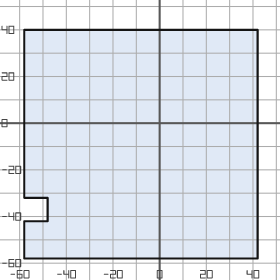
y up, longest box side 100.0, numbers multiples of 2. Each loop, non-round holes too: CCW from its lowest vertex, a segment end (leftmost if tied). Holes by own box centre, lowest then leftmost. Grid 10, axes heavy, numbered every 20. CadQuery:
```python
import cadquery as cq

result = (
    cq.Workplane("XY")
    .moveTo(-58.0, -58.0)
    .lineTo(42.0, -58.0)
    .lineTo(42.0, 40.0)
    .lineTo(-58.0, 40.0)
    .lineTo(-58.0, -32.0)
    .lineTo(-48.0, -32.0)
    .lineTo(-48.0, -42.0)
    .lineTo(-58.0, -42.0)
    .close()
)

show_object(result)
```